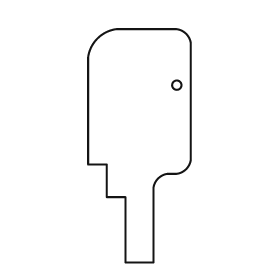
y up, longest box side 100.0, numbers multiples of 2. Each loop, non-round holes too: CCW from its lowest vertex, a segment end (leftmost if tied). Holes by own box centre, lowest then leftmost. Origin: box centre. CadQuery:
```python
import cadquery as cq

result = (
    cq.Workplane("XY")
    .moveTo(-6.0, -50.0)
    .lineTo(6.0, -50.0)
    .lineTo(6.0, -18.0)
    .threePointArc((8.0, -14.0), (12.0, -12.0))
    .lineTo(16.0, -12.0)
    .threePointArc((20.0, -10.0), (22.0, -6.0))
    .lineTo(22.0, 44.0)
    .threePointArc((20.0, 48.0), (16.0, 50.0))
    .lineTo(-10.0, 50.0)
    .threePointArc((-18.0, 46.0), (-22.0, 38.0))
    .lineTo(-22.0, -8.0)
    .lineTo(-14.0, -8.0)
    .lineTo(-14.0, -22.0)
    .lineTo(-6.0, -22.0)
    .close()
    .moveTo(16.0, 26.0)
    .circle(2.0)
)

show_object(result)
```